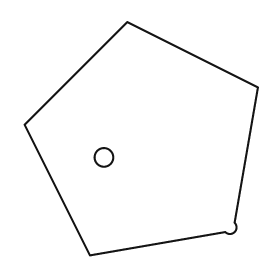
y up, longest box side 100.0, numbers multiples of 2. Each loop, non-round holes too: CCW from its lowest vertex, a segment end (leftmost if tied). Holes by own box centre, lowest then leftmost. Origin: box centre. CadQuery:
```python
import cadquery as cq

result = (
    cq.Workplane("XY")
    .moveTo(-22.0, -50.0)
    .lineTo(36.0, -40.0)
    .threePointArc((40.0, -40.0), (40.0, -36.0))
    .lineTo(50.0, 22.0)
    .lineTo(-6.0, 50.0)
    .lineTo(-50.0, 6.0)
    .close()
    .moveTo(-16.0, -8.0)
    .circle(4.0)
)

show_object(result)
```